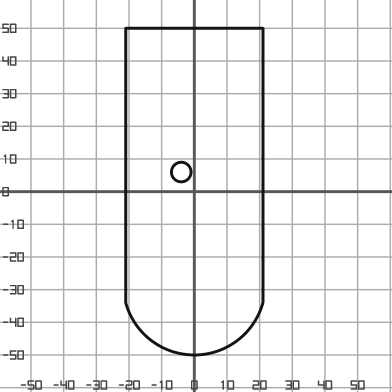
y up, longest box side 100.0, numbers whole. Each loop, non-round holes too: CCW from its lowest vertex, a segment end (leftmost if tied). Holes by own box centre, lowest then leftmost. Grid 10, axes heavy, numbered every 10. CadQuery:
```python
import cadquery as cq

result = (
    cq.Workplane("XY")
    .moveTo(-21.0, -34.0)
    .threePointArc((0.0, -50.0), (21.0, -34.0))
    .lineTo(21.0, 50.0)
    .lineTo(-21.0, 50.0)
    .close()
    .moveTo(-4.0, 6.0)
    .circle(3.0)
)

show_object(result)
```